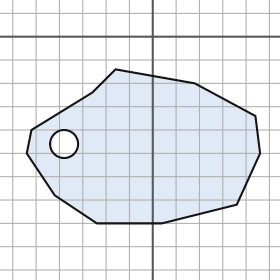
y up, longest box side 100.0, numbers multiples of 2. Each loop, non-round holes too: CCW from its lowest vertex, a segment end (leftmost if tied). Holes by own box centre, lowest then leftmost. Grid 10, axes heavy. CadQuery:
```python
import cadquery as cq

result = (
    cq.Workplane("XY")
    .moveTo(-24.0, -80.0)
    .lineTo(4.0, -80.0)
    .lineTo(36.0, -72.0)
    .lineTo(46.0, -50.0)
    .lineTo(44.0, -34.0)
    .lineTo(18.0, -20.0)
    .lineTo(-16.0, -14.0)
    .lineTo(-26.0, -24.0)
    .lineTo(-52.0, -40.0)
    .lineTo(-54.0, -50.0)
    .lineTo(-42.0, -68.0)
    .close()
    .moveTo(-38.0, -46.0)
    .circle(6.0)
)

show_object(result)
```